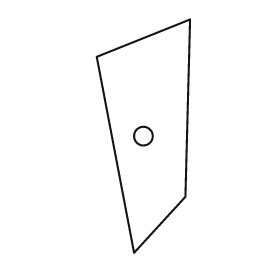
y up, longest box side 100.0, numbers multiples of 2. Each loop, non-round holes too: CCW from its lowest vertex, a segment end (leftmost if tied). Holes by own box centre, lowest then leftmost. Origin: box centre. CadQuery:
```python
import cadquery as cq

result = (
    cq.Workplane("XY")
    .moveTo(-4.0, -50.0)
    .lineTo(18.0, -26.0)
    .lineTo(20.0, 50.0)
    .lineTo(-20.0, 34.0)
    .close()
    .moveTo(0.0, 0.0)
    .circle(4.0)
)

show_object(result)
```